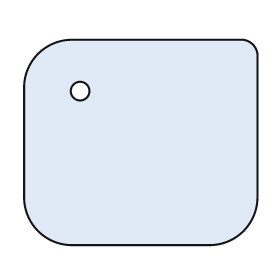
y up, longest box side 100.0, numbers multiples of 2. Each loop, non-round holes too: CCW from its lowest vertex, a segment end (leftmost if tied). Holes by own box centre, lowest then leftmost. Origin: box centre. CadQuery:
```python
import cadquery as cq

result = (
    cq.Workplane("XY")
    .moveTo(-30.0, -44.0)
    .lineTo(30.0, -44.0)
    .threePointArc((44.0, -38.0), (50.0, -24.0))
    .lineTo(50.0, 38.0)
    .threePointArc((48.0, 42.0), (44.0, 44.0))
    .lineTo(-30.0, 44.0)
    .threePointArc((-44.0, 38.0), (-50.0, 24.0))
    .lineTo(-50.0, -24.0)
    .threePointArc((-44.0, -38.0), (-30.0, -44.0))
    .close()
    .moveTo(-26.0, 22.0)
    .circle(4.0)
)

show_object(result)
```